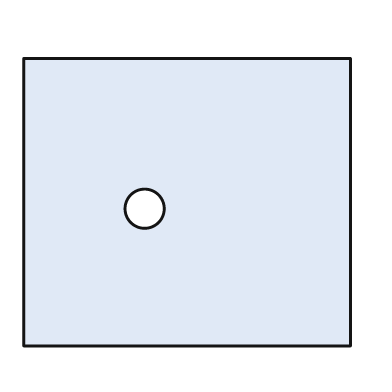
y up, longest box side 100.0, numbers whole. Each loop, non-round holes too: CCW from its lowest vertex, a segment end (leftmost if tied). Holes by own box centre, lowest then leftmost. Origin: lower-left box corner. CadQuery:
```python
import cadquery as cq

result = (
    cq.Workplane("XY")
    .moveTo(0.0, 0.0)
    .lineTo(100.0, 0.0)
    .lineTo(100.0, 88.0)
    .lineTo(0.0, 88.0)
    .close()
    .moveTo(37.0, 42.0)
    .circle(6.0)
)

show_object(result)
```